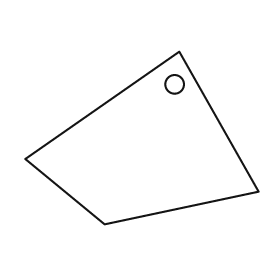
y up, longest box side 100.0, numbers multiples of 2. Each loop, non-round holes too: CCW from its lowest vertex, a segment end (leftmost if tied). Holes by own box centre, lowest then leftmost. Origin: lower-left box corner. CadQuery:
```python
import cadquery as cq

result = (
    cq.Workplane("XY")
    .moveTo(34.0, 0.0)
    .lineTo(100.0, 14.0)
    .lineTo(66.0, 74.0)
    .lineTo(0.0, 28.0)
    .close()
    .moveTo(64.0, 60.0)
    .circle(4.0)
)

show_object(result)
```